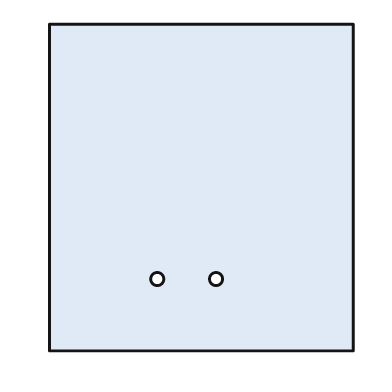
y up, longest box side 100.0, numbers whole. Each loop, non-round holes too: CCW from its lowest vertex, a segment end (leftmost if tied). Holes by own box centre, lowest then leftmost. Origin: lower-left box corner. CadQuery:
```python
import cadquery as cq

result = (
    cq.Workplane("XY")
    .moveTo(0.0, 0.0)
    .lineTo(93.0, 0.0)
    .lineTo(93.0, 100.0)
    .lineTo(0.0, 100.0)
    .close()
    .moveTo(33.0, 22.0)
    .circle(2.0)
    .moveTo(51.0, 22.0)
    .circle(2.0)
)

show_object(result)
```